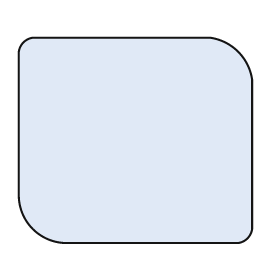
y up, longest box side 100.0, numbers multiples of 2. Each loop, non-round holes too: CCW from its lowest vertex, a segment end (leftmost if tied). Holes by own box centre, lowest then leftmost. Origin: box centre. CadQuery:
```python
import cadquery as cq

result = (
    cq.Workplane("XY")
    .moveTo(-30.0, -44.0)
    .lineTo(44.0, -44.0)
    .threePointArc((48.0, -42.0), (50.0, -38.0))
    .lineTo(50.0, 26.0)
    .threePointArc((44.0, 38.0), (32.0, 44.0))
    .lineTo(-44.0, 44.0)
    .threePointArc((-48.0, 42.0), (-50.0, 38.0))
    .lineTo(-50.0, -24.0)
    .threePointArc((-44.0, -38.0), (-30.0, -44.0))
    .close()
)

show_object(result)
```